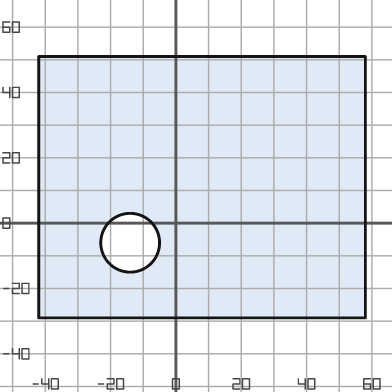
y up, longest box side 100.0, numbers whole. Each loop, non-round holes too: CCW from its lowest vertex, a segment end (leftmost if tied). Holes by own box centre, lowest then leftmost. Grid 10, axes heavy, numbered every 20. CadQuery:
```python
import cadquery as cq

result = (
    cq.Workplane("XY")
    .moveTo(-42.0, -29.0)
    .lineTo(58.0, -29.0)
    .lineTo(58.0, 51.0)
    .lineTo(-42.0, 51.0)
    .close()
    .moveTo(-14.0, -6.0)
    .circle(9.0)
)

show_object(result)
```